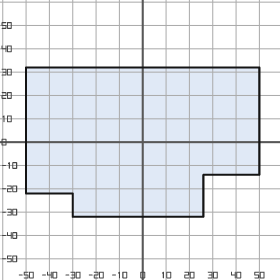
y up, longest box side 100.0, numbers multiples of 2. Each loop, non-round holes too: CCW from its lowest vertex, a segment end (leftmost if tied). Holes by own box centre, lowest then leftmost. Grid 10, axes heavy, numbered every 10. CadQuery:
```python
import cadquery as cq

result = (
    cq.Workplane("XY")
    .moveTo(-30.0, -32.0)
    .lineTo(26.0, -32.0)
    .lineTo(26.0, -14.0)
    .lineTo(50.0, -14.0)
    .lineTo(50.0, 32.0)
    .lineTo(-50.0, 32.0)
    .lineTo(-50.0, -22.0)
    .lineTo(-30.0, -22.0)
    .close()
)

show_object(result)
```